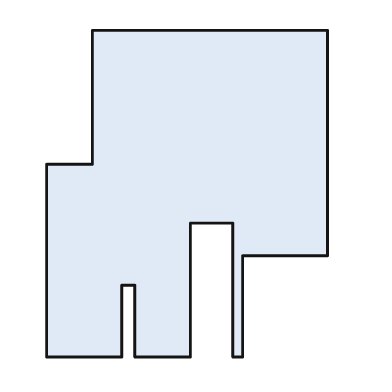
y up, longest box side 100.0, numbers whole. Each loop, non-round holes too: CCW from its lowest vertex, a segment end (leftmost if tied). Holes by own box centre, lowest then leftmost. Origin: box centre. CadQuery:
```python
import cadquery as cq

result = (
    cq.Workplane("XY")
    .moveTo(-43.0, -50.0)
    .lineTo(-20.0, -50.0)
    .lineTo(-20.0, -28.0)
    .lineTo(-16.0, -28.0)
    .lineTo(-16.0, -50.0)
    .lineTo(1.0, -50.0)
    .lineTo(1.0, -9.0)
    .lineTo(14.0, -9.0)
    .lineTo(14.0, -50.0)
    .lineTo(17.0, -50.0)
    .lineTo(17.0, -19.0)
    .lineTo(43.0, -19.0)
    .lineTo(43.0, 50.0)
    .lineTo(-29.0, 50.0)
    .lineTo(-29.0, 9.0)
    .lineTo(-43.0, 9.0)
    .close()
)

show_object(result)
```